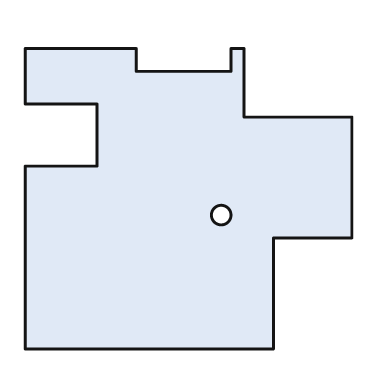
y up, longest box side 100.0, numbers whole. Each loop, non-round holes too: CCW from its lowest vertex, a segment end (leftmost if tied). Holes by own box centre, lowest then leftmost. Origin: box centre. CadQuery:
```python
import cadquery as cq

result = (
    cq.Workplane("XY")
    .moveTo(-50.0, -46.0)
    .lineTo(26.0, -46.0)
    .lineTo(26.0, -12.0)
    .lineTo(50.0, -12.0)
    .lineTo(50.0, 25.0)
    .lineTo(17.0, 25.0)
    .lineTo(17.0, 46.0)
    .lineTo(13.0, 46.0)
    .lineTo(13.0, 39.0)
    .lineTo(-16.0, 39.0)
    .lineTo(-16.0, 46.0)
    .lineTo(-50.0, 46.0)
    .lineTo(-50.0, 29.0)
    .lineTo(-28.0, 29.0)
    .lineTo(-28.0, 10.0)
    .lineTo(-50.0, 10.0)
    .close()
    .moveTo(10.0, -5.0)
    .circle(3.0)
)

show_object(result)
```